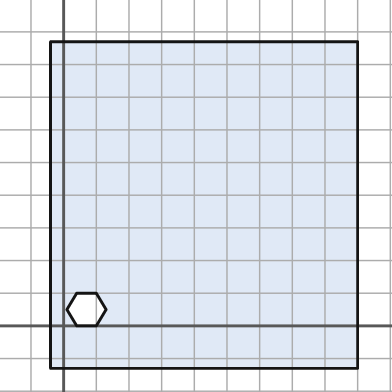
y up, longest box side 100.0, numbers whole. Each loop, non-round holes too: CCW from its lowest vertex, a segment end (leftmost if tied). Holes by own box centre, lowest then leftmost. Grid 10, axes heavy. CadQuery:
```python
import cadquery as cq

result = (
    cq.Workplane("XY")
    .moveTo(-4.0, -13.0)
    .lineTo(90.0, -13.0)
    .lineTo(90.0, 87.0)
    .lineTo(-4.0, 87.0)
    .close()
    .moveTo(4.0, 0.0)
    .lineTo(10.0, 0.0)
    .lineTo(13.0, 5.0)
    .lineTo(10.0, 10.0)
    .lineTo(4.0, 10.0)
    .lineTo(1.0, 5.0)
    .close()
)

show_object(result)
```